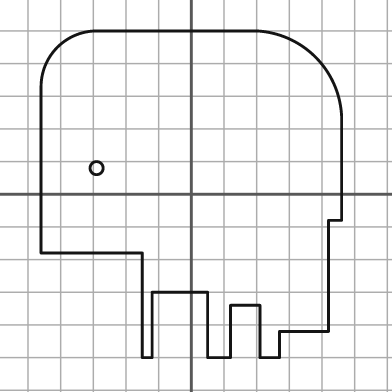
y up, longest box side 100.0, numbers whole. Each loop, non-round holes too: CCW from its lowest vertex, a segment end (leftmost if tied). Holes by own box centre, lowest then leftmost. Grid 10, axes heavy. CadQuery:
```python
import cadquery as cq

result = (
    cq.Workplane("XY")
    .moveTo(-15.0, -50.0)
    .lineTo(-12.0, -50.0)
    .lineTo(-12.0, -30.0)
    .lineTo(5.0, -30.0)
    .lineTo(5.0, -50.0)
    .lineTo(12.0, -50.0)
    .lineTo(12.0, -34.0)
    .lineTo(21.0, -34.0)
    .lineTo(21.0, -50.0)
    .lineTo(27.0, -50.0)
    .lineTo(27.0, -42.0)
    .lineTo(42.0, -42.0)
    .lineTo(42.0, -8.0)
    .lineTo(46.0, -8.0)
    .lineTo(46.0, 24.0)
    .threePointArc((38.0, 42.0), (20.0, 50.0))
    .lineTo(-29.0, 50.0)
    .threePointArc((-41.0, 45.0), (-46.0, 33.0))
    .lineTo(-46.0, -18.0)
    .lineTo(-15.0, -18.0)
    .close()
    .moveTo(-29.0, 8.0)
    .circle(2.0)
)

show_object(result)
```